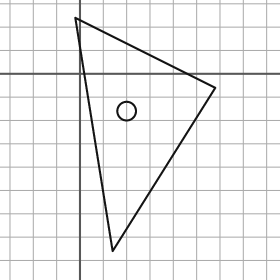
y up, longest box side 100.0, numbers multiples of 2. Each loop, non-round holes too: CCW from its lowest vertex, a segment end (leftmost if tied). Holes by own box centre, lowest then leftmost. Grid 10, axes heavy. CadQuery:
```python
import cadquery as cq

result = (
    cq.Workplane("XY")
    .moveTo(14.0, -76.0)
    .lineTo(58.0, -6.0)
    .lineTo(-2.0, 24.0)
    .close()
    .moveTo(20.0, -16.0)
    .circle(4.0)
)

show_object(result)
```